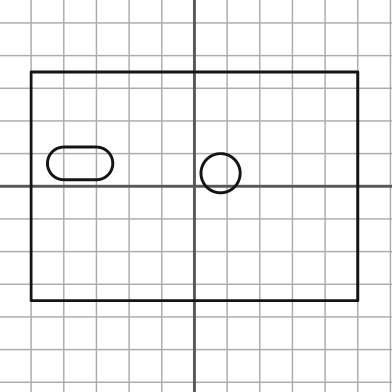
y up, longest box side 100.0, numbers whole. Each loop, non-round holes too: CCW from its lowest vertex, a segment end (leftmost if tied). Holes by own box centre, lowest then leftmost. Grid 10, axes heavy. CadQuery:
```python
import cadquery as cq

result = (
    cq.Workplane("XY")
    .moveTo(-50.0, -35.0)
    .lineTo(50.0, -35.0)
    .lineTo(50.0, 35.0)
    .lineTo(-50.0, 35.0)
    .close()
    .moveTo(8.0, 4.0)
    .circle(6.0)
    .moveTo(-40.0, 2.0)
    .lineTo(-30.0, 2.0)
    .threePointArc((-25.0, 7.0), (-30.0, 12.0))
    .lineTo(-40.0, 12.0)
    .threePointArc((-45.0, 7.0), (-40.0, 2.0))
    .close()
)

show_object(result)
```